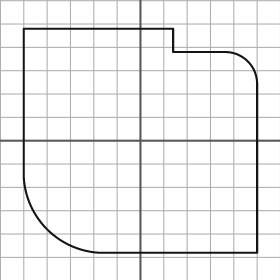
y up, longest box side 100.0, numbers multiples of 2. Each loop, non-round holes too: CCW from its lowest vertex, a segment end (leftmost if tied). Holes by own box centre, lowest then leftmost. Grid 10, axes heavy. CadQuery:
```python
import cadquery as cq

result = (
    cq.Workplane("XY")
    .moveTo(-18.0, -48.0)
    .lineTo(50.0, -48.0)
    .lineTo(50.0, 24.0)
    .threePointArc((46.0, 34.0), (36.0, 38.0))
    .lineTo(14.0, 38.0)
    .lineTo(14.0, 48.0)
    .lineTo(-50.0, 48.0)
    .lineTo(-50.0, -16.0)
    .threePointArc((-40.0, -38.0), (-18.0, -48.0))
    .close()
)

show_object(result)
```